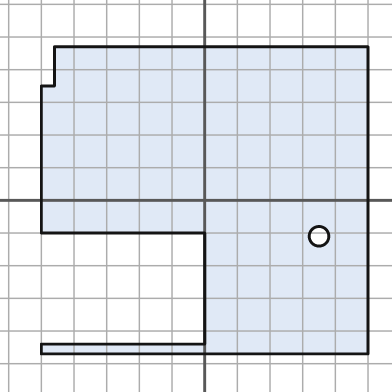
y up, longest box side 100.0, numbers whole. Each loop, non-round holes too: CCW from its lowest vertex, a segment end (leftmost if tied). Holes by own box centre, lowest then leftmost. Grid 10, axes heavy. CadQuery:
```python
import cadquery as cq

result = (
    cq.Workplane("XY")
    .moveTo(-50.0, -47.0)
    .lineTo(50.0, -47.0)
    .lineTo(50.0, 47.0)
    .lineTo(-46.0, 47.0)
    .lineTo(-46.0, 35.0)
    .lineTo(-50.0, 35.0)
    .lineTo(-50.0, -10.0)
    .lineTo(0.0, -10.0)
    .lineTo(0.0, -44.0)
    .lineTo(-50.0, -44.0)
    .close()
    .moveTo(35.0, -11.0)
    .circle(3.0)
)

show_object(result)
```